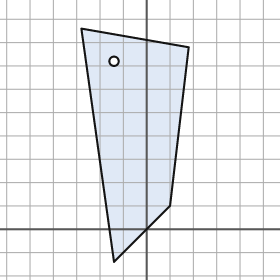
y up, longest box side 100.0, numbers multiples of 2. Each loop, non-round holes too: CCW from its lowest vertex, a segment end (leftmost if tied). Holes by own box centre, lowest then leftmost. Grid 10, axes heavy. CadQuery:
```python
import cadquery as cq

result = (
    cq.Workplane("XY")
    .moveTo(-14.0, -14.0)
    .lineTo(10.0, 10.0)
    .lineTo(18.0, 78.0)
    .lineTo(-28.0, 86.0)
    .close()
    .moveTo(-14.0, 72.0)
    .circle(2.0)
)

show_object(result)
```